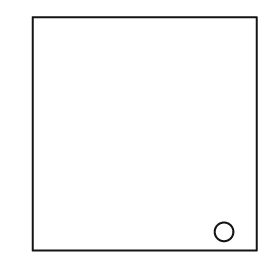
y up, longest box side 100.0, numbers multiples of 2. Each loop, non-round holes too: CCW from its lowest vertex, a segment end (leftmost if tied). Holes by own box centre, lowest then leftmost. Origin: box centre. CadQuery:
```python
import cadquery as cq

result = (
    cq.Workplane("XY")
    .moveTo(-48.0, -50.0)
    .lineTo(48.0, -50.0)
    .lineTo(48.0, 50.0)
    .lineTo(-48.0, 50.0)
    .close()
    .moveTo(34.0, -42.0)
    .circle(4.0)
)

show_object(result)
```